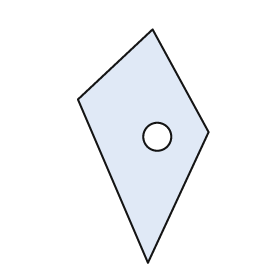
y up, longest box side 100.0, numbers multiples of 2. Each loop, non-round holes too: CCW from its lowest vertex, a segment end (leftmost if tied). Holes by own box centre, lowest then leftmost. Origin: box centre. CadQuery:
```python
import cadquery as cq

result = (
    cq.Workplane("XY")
    .moveTo(2.0, -50.0)
    .lineTo(28.0, 6.0)
    .lineTo(4.0, 50.0)
    .lineTo(-28.0, 20.0)
    .close()
    .moveTo(6.0, 4.0)
    .circle(6.0)
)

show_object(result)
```